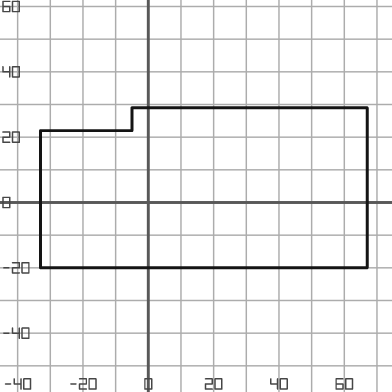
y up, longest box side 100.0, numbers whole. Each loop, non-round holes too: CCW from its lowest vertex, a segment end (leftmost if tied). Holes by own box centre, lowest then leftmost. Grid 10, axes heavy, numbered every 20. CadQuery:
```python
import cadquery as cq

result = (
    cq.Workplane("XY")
    .moveTo(-33.0, -20.0)
    .lineTo(67.0, -20.0)
    .lineTo(67.0, 29.0)
    .lineTo(-5.0, 29.0)
    .lineTo(-5.0, 22.0)
    .lineTo(-33.0, 22.0)
    .close()
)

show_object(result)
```